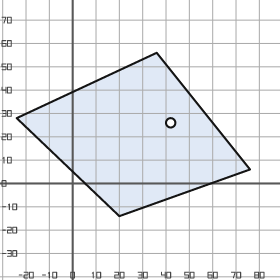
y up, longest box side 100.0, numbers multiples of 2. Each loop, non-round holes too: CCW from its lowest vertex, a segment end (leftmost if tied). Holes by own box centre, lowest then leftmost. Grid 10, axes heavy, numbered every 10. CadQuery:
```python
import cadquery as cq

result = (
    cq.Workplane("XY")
    .moveTo(20.0, -14.0)
    .lineTo(76.0, 6.0)
    .lineTo(36.0, 56.0)
    .lineTo(-24.0, 28.0)
    .close()
    .moveTo(42.0, 26.0)
    .circle(2.0)
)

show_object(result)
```